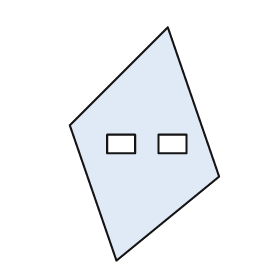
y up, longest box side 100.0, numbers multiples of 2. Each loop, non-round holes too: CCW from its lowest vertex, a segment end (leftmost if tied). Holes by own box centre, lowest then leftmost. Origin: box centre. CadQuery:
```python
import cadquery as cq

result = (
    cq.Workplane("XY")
    .moveTo(-12.0, -50.0)
    .lineTo(32.0, -14.0)
    .lineTo(10.0, 50.0)
    .lineTo(-32.0, 8.0)
    .close()
    .moveTo(-16.0, -4.0)
    .lineTo(-4.0, -4.0)
    .lineTo(-4.0, 4.0)
    .lineTo(-16.0, 4.0)
    .close()
    .moveTo(6.0, -4.0)
    .lineTo(18.0, -4.0)
    .lineTo(18.0, 4.0)
    .lineTo(6.0, 4.0)
    .close()
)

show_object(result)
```